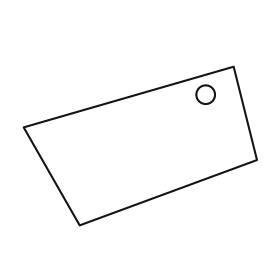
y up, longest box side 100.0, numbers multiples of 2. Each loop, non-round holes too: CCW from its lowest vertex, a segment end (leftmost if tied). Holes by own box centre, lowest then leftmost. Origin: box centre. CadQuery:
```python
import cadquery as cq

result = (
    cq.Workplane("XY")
    .moveTo(-26.0, -34.0)
    .lineTo(50.0, -6.0)
    .lineTo(40.0, 34.0)
    .lineTo(-50.0, 8.0)
    .close()
    .moveTo(28.0, 22.0)
    .circle(4.0)
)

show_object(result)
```